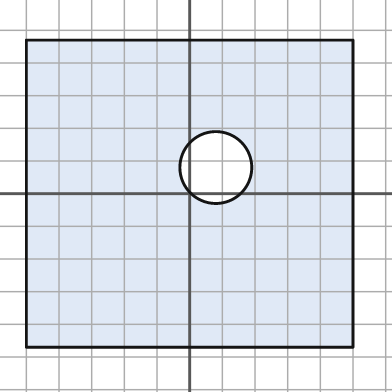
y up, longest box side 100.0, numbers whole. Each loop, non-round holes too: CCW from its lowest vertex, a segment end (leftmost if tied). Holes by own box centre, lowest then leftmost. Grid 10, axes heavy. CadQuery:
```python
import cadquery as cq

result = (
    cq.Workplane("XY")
    .moveTo(-50.0, -47.0)
    .lineTo(50.0, -47.0)
    .lineTo(50.0, 47.0)
    .lineTo(-50.0, 47.0)
    .close()
    .moveTo(8.0, 8.0)
    .circle(11.0)
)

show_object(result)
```